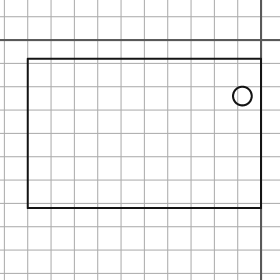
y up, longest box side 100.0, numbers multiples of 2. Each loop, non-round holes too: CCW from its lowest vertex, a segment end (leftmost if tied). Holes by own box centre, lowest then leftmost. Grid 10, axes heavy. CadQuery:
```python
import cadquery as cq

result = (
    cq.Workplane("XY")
    .moveTo(-100.0, -72.0)
    .lineTo(0.0, -72.0)
    .lineTo(0.0, -8.0)
    .lineTo(-100.0, -8.0)
    .close()
    .moveTo(-8.0, -24.0)
    .circle(4.0)
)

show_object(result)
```